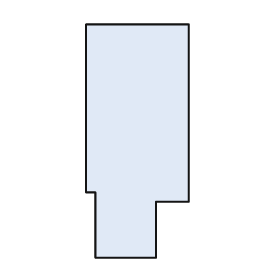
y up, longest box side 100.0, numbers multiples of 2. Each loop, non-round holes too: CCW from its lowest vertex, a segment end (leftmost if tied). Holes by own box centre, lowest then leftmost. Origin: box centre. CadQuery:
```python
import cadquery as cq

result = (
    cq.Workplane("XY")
    .moveTo(-18.0, -50.0)
    .lineTo(8.0, -50.0)
    .lineTo(8.0, -26.0)
    .lineTo(22.0, -26.0)
    .lineTo(22.0, 50.0)
    .lineTo(-22.0, 50.0)
    .lineTo(-22.0, -22.0)
    .lineTo(-18.0, -22.0)
    .close()
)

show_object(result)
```